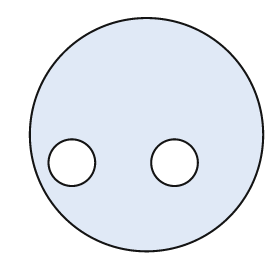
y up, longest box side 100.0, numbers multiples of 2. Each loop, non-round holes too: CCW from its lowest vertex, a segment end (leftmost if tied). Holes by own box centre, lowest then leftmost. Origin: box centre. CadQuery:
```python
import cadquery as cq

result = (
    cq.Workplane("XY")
    .moveTo(0.0, 0.0)
    .circle(50.0)
    .moveTo(-32.0, -12.0)
    .circle(10.0)
    .moveTo(12.0, -12.0)
    .circle(10.0)
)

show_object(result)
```